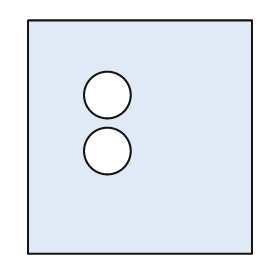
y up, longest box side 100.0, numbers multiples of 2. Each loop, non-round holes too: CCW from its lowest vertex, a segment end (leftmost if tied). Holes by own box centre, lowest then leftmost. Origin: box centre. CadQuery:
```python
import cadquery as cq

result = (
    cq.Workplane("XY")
    .moveTo(-48.0, -50.0)
    .lineTo(48.0, -50.0)
    .lineTo(48.0, 50.0)
    .lineTo(-48.0, 50.0)
    .close()
    .moveTo(-14.0, -6.0)
    .circle(10.0)
    .moveTo(-14.0, 18.0)
    .circle(10.0)
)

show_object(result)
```